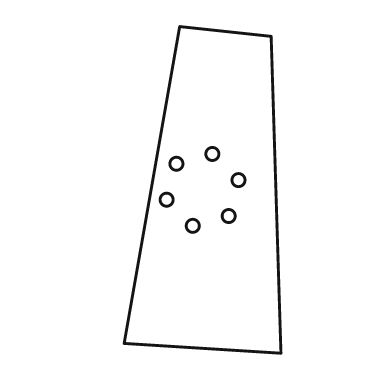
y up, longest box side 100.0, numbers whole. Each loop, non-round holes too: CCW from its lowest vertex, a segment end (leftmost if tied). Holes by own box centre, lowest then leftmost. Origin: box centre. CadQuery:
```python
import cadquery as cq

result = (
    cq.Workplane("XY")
    .moveTo(24.0, -50.0)
    .lineTo(21.0, 47.0)
    .lineTo(-7.0, 50.0)
    .lineTo(-24.0, -47.0)
    .close()
    .moveTo(-3.0, -11.0)
    .circle(2.0)
    .moveTo(8.0, -8.0)
    .circle(2.0)
    .moveTo(-11.0, -3.0)
    .circle(2.0)
    .moveTo(11.0, 3.0)
    .circle(2.0)
    .moveTo(-8.0, 8.0)
    .circle(2.0)
    .moveTo(3.0, 11.0)
    .circle(2.0)
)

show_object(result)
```